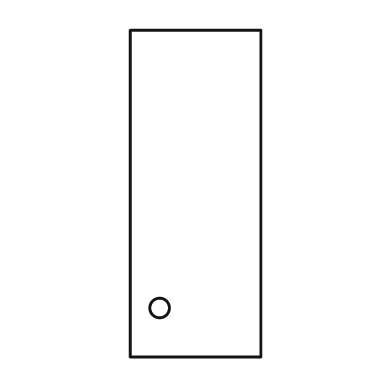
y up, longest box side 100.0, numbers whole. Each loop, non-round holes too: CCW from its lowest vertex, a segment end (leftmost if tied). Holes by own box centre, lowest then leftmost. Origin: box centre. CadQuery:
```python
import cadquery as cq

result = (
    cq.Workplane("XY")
    .moveTo(-20.0, -50.0)
    .lineTo(20.0, -50.0)
    .lineTo(20.0, 50.0)
    .lineTo(-20.0, 50.0)
    .close()
    .moveTo(-11.0, -35.0)
    .circle(3.0)
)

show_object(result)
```